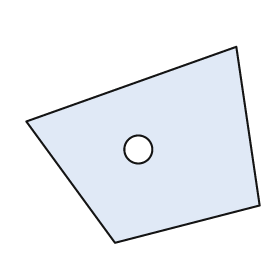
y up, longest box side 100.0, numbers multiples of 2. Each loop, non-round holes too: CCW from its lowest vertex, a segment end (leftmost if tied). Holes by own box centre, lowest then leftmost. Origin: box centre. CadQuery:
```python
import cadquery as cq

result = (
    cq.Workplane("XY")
    .moveTo(-12.0, -42.0)
    .lineTo(50.0, -26.0)
    .lineTo(40.0, 42.0)
    .lineTo(-50.0, 10.0)
    .close()
    .moveTo(-2.0, -2.0)
    .circle(6.0)
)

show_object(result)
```